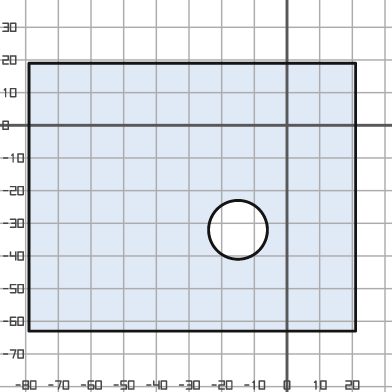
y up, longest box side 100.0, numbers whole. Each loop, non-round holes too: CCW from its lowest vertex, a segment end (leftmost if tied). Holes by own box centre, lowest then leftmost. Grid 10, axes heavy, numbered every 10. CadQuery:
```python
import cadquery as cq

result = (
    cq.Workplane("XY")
    .moveTo(-79.0, -63.0)
    .lineTo(21.0, -63.0)
    .lineTo(21.0, 19.0)
    .lineTo(-79.0, 19.0)
    .close()
    .moveTo(-15.0, -32.0)
    .circle(9.0)
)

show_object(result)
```